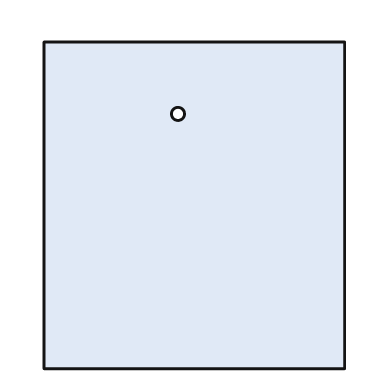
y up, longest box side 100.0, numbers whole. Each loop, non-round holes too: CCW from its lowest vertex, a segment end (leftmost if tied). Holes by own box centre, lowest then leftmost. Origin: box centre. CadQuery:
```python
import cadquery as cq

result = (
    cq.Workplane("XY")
    .moveTo(-46.0, -50.0)
    .lineTo(46.0, -50.0)
    .lineTo(46.0, 50.0)
    .lineTo(-46.0, 50.0)
    .close()
    .moveTo(-5.0, 28.0)
    .circle(2.0)
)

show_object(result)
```